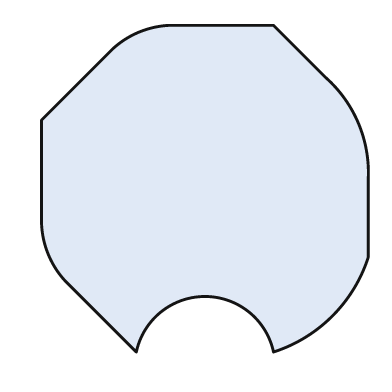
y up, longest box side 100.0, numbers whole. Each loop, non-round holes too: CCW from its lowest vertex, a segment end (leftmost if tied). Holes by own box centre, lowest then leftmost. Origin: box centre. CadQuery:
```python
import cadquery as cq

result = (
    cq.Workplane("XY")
    .moveTo(-21.0, -50.0)
    .threePointArc((0.0, -33.0), (21.0, -50.0))
    .threePointArc((39.0, -39.0), (50.0, -21.0))
    .lineTo(50.0, 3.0)
    .threePointArc((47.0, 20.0), (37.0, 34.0))
    .lineTo(21.0, 50.0)
    .lineTo(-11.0, 50.0)
    .threePointArc((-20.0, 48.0), (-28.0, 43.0))
    .lineTo(-50.0, 21.0)
    .lineTo(-50.0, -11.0)
    .threePointArc((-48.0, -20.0), (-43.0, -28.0))
    .close()
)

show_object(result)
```